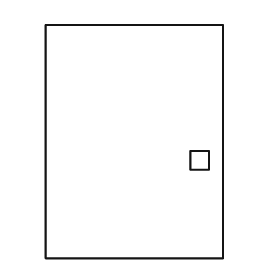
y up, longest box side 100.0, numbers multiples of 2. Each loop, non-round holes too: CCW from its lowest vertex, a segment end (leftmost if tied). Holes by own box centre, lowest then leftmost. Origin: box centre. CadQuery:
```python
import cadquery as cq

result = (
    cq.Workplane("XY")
    .moveTo(-38.0, -50.0)
    .lineTo(38.0, -50.0)
    .lineTo(38.0, 50.0)
    .lineTo(-38.0, 50.0)
    .close()
    .moveTo(24.0, -12.0)
    .lineTo(32.0, -12.0)
    .lineTo(32.0, -4.0)
    .lineTo(24.0, -4.0)
    .close()
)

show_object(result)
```